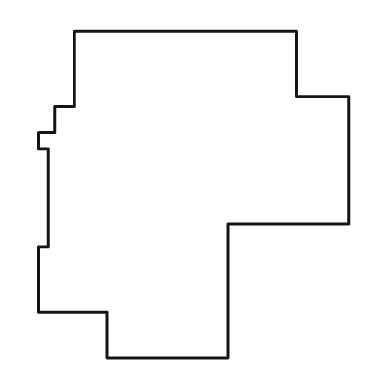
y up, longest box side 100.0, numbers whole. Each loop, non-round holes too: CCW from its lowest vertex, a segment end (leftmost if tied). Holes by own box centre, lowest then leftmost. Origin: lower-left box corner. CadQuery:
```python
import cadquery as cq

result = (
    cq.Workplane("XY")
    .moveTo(21.0, 0.0)
    .lineTo(58.0, 0.0)
    .lineTo(58.0, 41.0)
    .lineTo(95.0, 41.0)
    .lineTo(95.0, 80.0)
    .lineTo(79.0, 80.0)
    .lineTo(79.0, 100.0)
    .lineTo(11.0, 100.0)
    .lineTo(11.0, 77.0)
    .lineTo(5.0, 77.0)
    .lineTo(5.0, 69.0)
    .lineTo(0.0, 69.0)
    .lineTo(0.0, 64.0)
    .lineTo(3.0, 64.0)
    .lineTo(3.0, 34.0)
    .lineTo(0.0, 34.0)
    .lineTo(0.0, 14.0)
    .lineTo(21.0, 14.0)
    .close()
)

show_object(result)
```